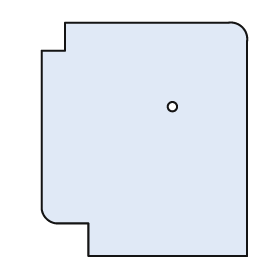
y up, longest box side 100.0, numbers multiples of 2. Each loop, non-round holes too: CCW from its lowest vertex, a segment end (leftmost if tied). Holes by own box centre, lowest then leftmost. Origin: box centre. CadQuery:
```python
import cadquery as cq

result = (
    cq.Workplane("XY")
    .moveTo(-24.0, -50.0)
    .lineTo(44.0, -50.0)
    .lineTo(44.0, 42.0)
    .threePointArc((42.0, 48.0), (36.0, 50.0))
    .lineTo(-34.0, 50.0)
    .lineTo(-34.0, 38.0)
    .lineTo(-44.0, 38.0)
    .lineTo(-44.0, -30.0)
    .threePointArc((-42.0, -34.0), (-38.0, -36.0))
    .lineTo(-24.0, -36.0)
    .close()
    .moveTo(12.0, 14.0)
    .circle(2.0)
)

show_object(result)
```